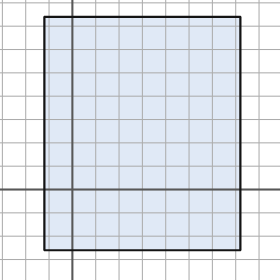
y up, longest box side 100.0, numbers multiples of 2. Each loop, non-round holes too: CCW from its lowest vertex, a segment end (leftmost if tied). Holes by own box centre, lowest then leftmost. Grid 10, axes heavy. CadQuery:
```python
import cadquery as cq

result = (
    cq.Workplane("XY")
    .moveTo(-12.0, -26.0)
    .lineTo(72.0, -26.0)
    .lineTo(72.0, 74.0)
    .lineTo(-12.0, 74.0)
    .close()
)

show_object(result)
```